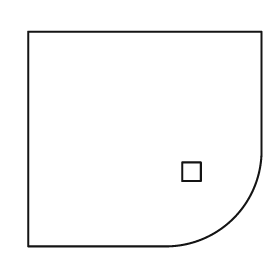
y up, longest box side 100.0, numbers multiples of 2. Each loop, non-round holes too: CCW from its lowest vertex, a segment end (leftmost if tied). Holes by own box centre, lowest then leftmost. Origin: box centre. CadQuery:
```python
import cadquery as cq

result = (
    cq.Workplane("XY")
    .moveTo(-50.0, -46.0)
    .lineTo(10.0, -46.0)
    .threePointArc((38.0, -34.0), (50.0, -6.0))
    .lineTo(50.0, 46.0)
    .lineTo(-50.0, 46.0)
    .close()
    .moveTo(16.0, -18.0)
    .lineTo(24.0, -18.0)
    .lineTo(24.0, -10.0)
    .lineTo(16.0, -10.0)
    .close()
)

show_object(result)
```